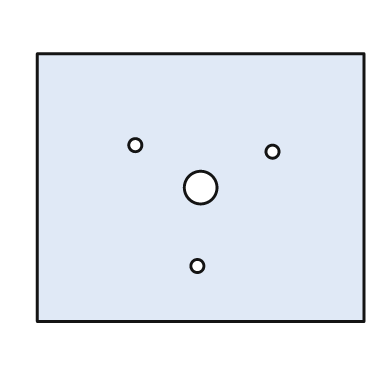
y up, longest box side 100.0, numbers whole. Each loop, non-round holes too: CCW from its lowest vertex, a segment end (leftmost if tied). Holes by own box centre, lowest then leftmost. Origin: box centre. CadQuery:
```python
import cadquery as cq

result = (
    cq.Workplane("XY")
    .moveTo(-50.0, -41.0)
    .lineTo(50.0, -41.0)
    .lineTo(50.0, 41.0)
    .lineTo(-50.0, 41.0)
    .close()
    .moveTo(-1.0, -24.0)
    .circle(2.0)
    .moveTo(0.0, 0.0)
    .circle(5.0)
    .moveTo(22.0, 11.0)
    .circle(2.0)
    .moveTo(-20.0, 13.0)
    .circle(2.0)
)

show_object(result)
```